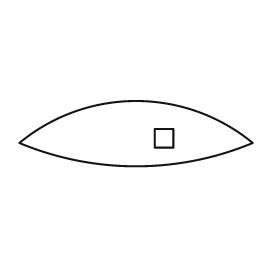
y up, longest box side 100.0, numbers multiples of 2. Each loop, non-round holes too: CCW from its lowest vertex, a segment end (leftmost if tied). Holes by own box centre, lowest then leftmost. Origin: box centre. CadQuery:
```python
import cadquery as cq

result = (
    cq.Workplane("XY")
    .moveTo(-50.0, -4.0)
    .threePointArc((0.0, -14.0), (50.0, -4.0))
    .threePointArc((0.0, 14.0), (-50.0, -4.0))
    .close()
    .moveTo(8.0, -6.0)
    .lineTo(16.0, -6.0)
    .lineTo(16.0, 2.0)
    .lineTo(8.0, 2.0)
    .close()
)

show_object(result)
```